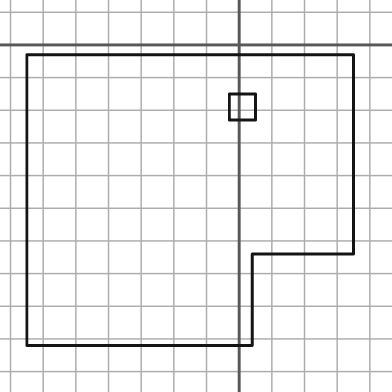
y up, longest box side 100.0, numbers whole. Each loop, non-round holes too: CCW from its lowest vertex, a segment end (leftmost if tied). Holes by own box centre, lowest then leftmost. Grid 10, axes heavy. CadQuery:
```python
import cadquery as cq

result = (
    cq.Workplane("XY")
    .moveTo(-65.0, -92.0)
    .lineTo(4.0, -92.0)
    .lineTo(4.0, -64.0)
    .lineTo(35.0, -64.0)
    .lineTo(35.0, -3.0)
    .lineTo(-65.0, -3.0)
    .close()
    .moveTo(-3.0, -23.0)
    .lineTo(5.0, -23.0)
    .lineTo(5.0, -15.0)
    .lineTo(-3.0, -15.0)
    .close()
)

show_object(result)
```